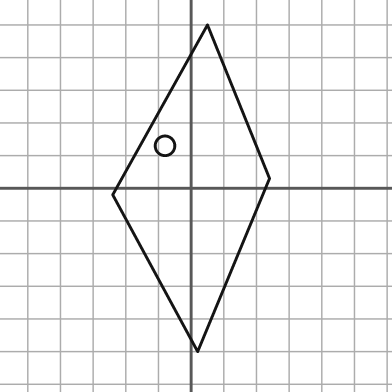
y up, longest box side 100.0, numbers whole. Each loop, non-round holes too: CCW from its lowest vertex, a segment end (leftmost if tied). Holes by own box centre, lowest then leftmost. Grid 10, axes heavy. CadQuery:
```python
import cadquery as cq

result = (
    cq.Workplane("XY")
    .moveTo(2.0, -50.0)
    .lineTo(24.0, 3.0)
    .lineTo(5.0, 50.0)
    .lineTo(-24.0, -2.0)
    .close()
    .moveTo(-8.0, 13.0)
    .circle(3.0)
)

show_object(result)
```